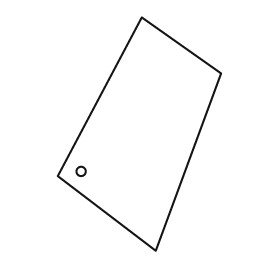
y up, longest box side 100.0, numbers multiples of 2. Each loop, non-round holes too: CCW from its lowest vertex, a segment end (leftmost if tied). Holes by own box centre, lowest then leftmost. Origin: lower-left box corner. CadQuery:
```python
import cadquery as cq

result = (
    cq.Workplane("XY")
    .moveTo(42.0, 0.0)
    .lineTo(70.0, 76.0)
    .lineTo(36.0, 100.0)
    .lineTo(0.0, 32.0)
    .close()
    .moveTo(10.0, 34.0)
    .circle(2.0)
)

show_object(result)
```